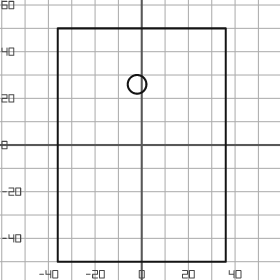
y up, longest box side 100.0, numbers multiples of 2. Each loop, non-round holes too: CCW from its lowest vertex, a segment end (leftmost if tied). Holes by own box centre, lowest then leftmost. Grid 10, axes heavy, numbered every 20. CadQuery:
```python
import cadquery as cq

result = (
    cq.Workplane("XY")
    .moveTo(-36.0, -50.0)
    .lineTo(36.0, -50.0)
    .lineTo(36.0, 50.0)
    .lineTo(-36.0, 50.0)
    .close()
    .moveTo(-2.0, 26.0)
    .circle(4.0)
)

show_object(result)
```